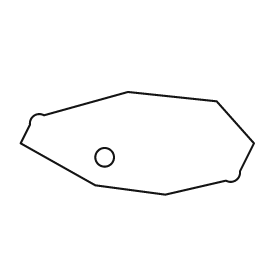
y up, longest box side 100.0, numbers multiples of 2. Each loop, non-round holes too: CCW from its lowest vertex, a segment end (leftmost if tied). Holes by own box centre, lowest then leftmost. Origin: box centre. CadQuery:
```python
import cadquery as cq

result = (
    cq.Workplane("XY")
    .moveTo(12.0, -22.0)
    .lineTo(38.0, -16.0)
    .threePointArc((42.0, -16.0), (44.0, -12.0))
    .lineTo(50.0, 0.0)
    .lineTo(34.0, 18.0)
    .lineTo(-4.0, 22.0)
    .lineTo(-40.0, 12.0)
    .threePointArc((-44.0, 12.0), (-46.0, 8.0))
    .lineTo(-50.0, 0.0)
    .lineTo(-18.0, -18.0)
    .close()
    .moveTo(-14.0, -6.0)
    .circle(4.0)
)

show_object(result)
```